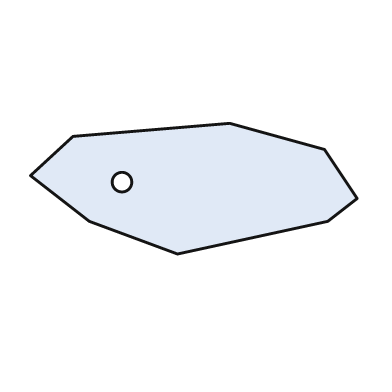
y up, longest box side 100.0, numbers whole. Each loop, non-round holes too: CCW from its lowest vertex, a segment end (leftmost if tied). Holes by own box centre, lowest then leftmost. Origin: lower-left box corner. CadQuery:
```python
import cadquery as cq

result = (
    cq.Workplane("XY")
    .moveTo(45.0, 0.0)
    .lineTo(91.0, 10.0)
    .lineTo(100.0, 17.0)
    .lineTo(90.0, 32.0)
    .lineTo(61.0, 40.0)
    .lineTo(13.0, 36.0)
    .lineTo(0.0, 24.0)
    .lineTo(18.0, 10.0)
    .close()
    .moveTo(28.0, 22.0)
    .circle(3.0)
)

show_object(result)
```